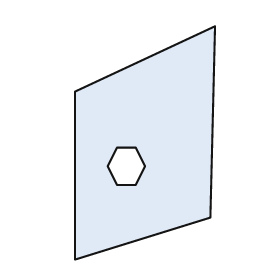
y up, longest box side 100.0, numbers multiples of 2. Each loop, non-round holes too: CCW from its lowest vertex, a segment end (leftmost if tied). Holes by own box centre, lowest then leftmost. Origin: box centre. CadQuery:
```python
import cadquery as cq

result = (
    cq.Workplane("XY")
    .moveTo(-30.0, -50.0)
    .lineTo(28.0, -32.0)
    .lineTo(30.0, 50.0)
    .lineTo(-30.0, 22.0)
    .close()
    .moveTo(-12.0, -18.0)
    .lineTo(-4.0, -18.0)
    .lineTo(0.0, -10.0)
    .lineTo(-4.0, -2.0)
    .lineTo(-12.0, -2.0)
    .lineTo(-16.0, -10.0)
    .close()
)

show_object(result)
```